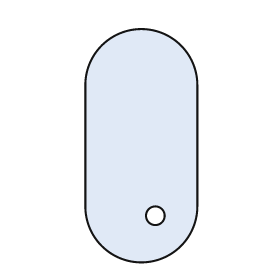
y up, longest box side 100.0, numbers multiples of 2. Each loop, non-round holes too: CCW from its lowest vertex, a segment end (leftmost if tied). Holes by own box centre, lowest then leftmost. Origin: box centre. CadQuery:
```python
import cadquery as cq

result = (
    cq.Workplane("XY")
    .moveTo(-24.0, -26.0)
    .threePointArc((0.0, -50.0), (24.0, -26.0))
    .lineTo(24.0, 26.0)
    .threePointArc((0.0, 50.0), (-24.0, 26.0))
    .close()
    .moveTo(6.0, -30.0)
    .circle(4.0)
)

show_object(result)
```